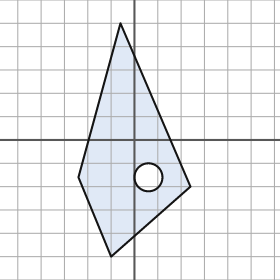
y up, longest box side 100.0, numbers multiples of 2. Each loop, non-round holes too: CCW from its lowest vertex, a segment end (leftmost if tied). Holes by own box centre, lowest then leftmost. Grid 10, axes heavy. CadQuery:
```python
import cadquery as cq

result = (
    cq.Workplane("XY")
    .moveTo(-10.0, -50.0)
    .lineTo(24.0, -20.0)
    .lineTo(-6.0, 50.0)
    .lineTo(-24.0, -16.0)
    .close()
    .moveTo(6.0, -16.0)
    .circle(6.0)
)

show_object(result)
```